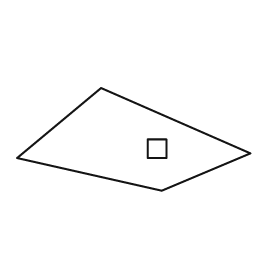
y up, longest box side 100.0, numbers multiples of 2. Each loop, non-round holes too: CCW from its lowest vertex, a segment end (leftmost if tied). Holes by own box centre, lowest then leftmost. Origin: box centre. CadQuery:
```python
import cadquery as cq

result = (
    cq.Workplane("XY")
    .moveTo(12.0, -22.0)
    .lineTo(50.0, -6.0)
    .lineTo(-14.0, 22.0)
    .lineTo(-50.0, -8.0)
    .close()
    .moveTo(6.0, -8.0)
    .lineTo(14.0, -8.0)
    .lineTo(14.0, 0.0)
    .lineTo(6.0, 0.0)
    .close()
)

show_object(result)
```